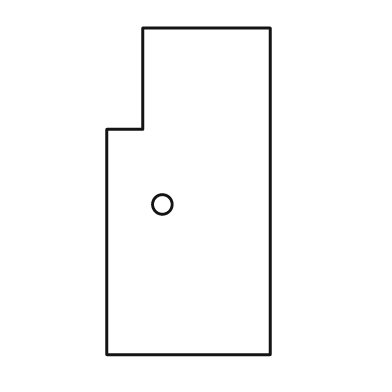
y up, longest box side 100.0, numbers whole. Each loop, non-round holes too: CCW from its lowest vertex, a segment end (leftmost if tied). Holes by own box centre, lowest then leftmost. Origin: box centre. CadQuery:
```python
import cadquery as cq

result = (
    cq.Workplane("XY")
    .moveTo(-25.0, -50.0)
    .lineTo(25.0, -50.0)
    .lineTo(25.0, 50.0)
    .lineTo(-14.0, 50.0)
    .lineTo(-14.0, 19.0)
    .lineTo(-25.0, 19.0)
    .close()
    .moveTo(-8.0, -4.0)
    .circle(3.0)
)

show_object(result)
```